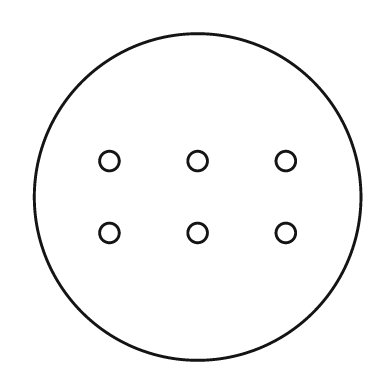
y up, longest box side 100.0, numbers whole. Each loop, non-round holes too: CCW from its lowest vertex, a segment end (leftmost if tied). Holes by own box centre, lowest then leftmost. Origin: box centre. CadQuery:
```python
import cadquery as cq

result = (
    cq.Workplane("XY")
    .moveTo(0.0, 0.0)
    .circle(50.0)
    .moveTo(-27.0, -11.0)
    .circle(3.0)
    .moveTo(0.0, -11.0)
    .circle(3.0)
    .moveTo(27.0, -11.0)
    .circle(3.0)
    .moveTo(-27.0, 11.0)
    .circle(3.0)
    .moveTo(0.0, 11.0)
    .circle(3.0)
    .moveTo(27.0, 11.0)
    .circle(3.0)
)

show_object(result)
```